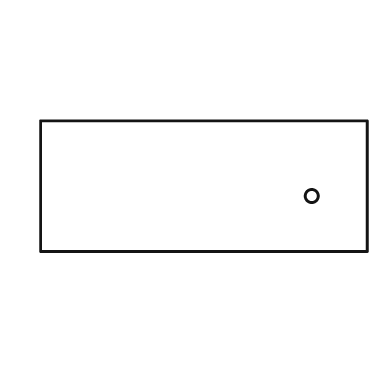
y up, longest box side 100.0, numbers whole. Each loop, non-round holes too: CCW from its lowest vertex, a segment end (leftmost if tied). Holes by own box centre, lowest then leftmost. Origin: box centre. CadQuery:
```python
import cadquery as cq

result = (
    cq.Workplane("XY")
    .moveTo(-50.0, -20.0)
    .lineTo(50.0, -20.0)
    .lineTo(50.0, 20.0)
    .lineTo(-50.0, 20.0)
    .close()
    .moveTo(33.0, -3.0)
    .circle(2.0)
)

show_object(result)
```